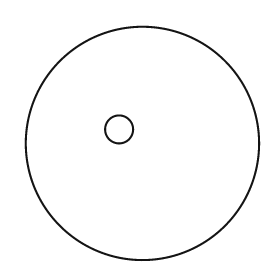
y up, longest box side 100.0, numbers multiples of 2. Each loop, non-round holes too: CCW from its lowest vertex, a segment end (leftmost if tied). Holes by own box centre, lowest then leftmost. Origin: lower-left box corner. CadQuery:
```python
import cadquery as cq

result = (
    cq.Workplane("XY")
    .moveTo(50.0, 50.0)
    .circle(50.0)
    .moveTo(40.0, 56.0)
    .circle(6.0)
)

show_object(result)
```